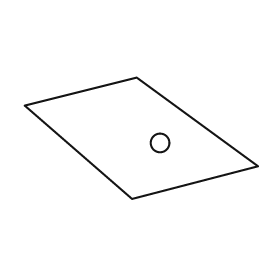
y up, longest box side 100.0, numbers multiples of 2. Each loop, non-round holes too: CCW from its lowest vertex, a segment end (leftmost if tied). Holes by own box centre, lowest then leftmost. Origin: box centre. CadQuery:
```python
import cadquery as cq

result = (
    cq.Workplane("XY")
    .moveTo(-4.0, -26.0)
    .lineTo(50.0, -12.0)
    .lineTo(-2.0, 26.0)
    .lineTo(-50.0, 14.0)
    .close()
    .moveTo(8.0, -2.0)
    .circle(4.0)
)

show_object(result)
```